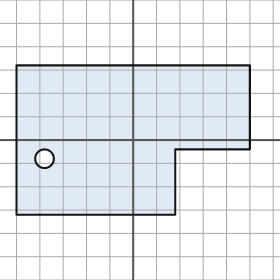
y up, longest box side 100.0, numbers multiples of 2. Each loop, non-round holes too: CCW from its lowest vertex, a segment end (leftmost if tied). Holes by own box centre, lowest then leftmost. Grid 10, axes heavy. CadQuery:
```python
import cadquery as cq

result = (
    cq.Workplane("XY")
    .moveTo(-50.0, -32.0)
    .lineTo(18.0, -32.0)
    .lineTo(18.0, -4.0)
    .lineTo(50.0, -4.0)
    .lineTo(50.0, 32.0)
    .lineTo(-50.0, 32.0)
    .close()
    .moveTo(-38.0, -8.0)
    .circle(4.0)
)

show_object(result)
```